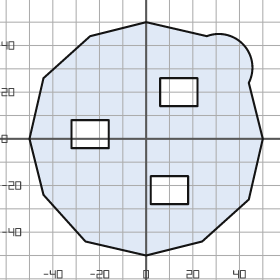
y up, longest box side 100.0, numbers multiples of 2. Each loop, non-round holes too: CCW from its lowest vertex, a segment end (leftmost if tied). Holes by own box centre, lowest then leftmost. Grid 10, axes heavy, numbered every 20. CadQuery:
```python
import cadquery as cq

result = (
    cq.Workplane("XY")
    .moveTo(0.0, -50.0)
    .lineTo(24.0, -44.0)
    .lineTo(44.0, -26.0)
    .lineTo(50.0, 0.0)
    .lineTo(44.0, 24.0)
    .threePointArc((42.0, 40.0), (26.0, 44.0))
    .lineTo(0.0, 50.0)
    .lineTo(-24.0, 44.0)
    .lineTo(-44.0, 26.0)
    .lineTo(-50.0, 0.0)
    .lineTo(-44.0, -24.0)
    .lineTo(-26.0, -44.0)
    .close()
    .moveTo(2.0, -28.0)
    .lineTo(18.0, -28.0)
    .lineTo(18.0, -16.0)
    .lineTo(2.0, -16.0)
    .close()
    .moveTo(-32.0, -4.0)
    .lineTo(-16.0, -4.0)
    .lineTo(-16.0, 8.0)
    .lineTo(-32.0, 8.0)
    .close()
    .moveTo(6.0, 14.0)
    .lineTo(22.0, 14.0)
    .lineTo(22.0, 26.0)
    .lineTo(6.0, 26.0)
    .close()
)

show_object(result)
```